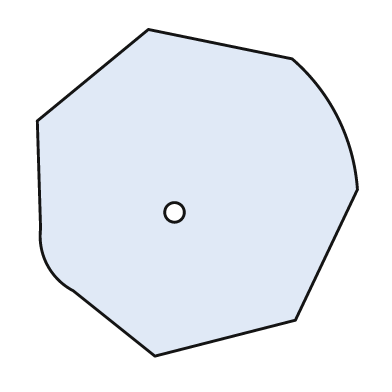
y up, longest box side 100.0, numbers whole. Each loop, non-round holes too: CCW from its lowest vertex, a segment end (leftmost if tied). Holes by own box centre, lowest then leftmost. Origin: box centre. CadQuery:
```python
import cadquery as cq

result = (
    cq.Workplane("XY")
    .moveTo(-13.0, -50.0)
    .lineTo(30.0, -39.0)
    .lineTo(49.0, 1.0)
    .threePointArc((43.0, 23.0), (29.0, 41.0))
    .lineTo(-15.0, 50.0)
    .lineTo(-49.0, 22.0)
    .lineTo(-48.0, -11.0)
    .threePointArc((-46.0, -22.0), (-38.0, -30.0))
    .close()
    .moveTo(-7.0, -6.0)
    .circle(3.0)
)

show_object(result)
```